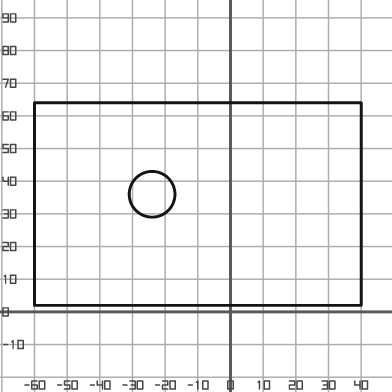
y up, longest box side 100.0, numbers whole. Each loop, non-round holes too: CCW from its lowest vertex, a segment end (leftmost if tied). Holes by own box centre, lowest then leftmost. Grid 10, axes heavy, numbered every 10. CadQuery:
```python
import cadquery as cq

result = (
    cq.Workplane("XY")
    .moveTo(-60.0, 2.0)
    .lineTo(40.0, 2.0)
    .lineTo(40.0, 64.0)
    .lineTo(-60.0, 64.0)
    .close()
    .moveTo(-24.0, 36.0)
    .circle(7.0)
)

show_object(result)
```